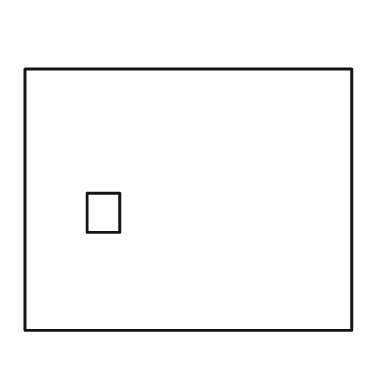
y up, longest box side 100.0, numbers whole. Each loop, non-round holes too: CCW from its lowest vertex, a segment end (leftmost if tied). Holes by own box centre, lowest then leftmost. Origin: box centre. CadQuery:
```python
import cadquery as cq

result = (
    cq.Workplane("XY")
    .moveTo(-50.0, -40.0)
    .lineTo(50.0, -40.0)
    .lineTo(50.0, 40.0)
    .lineTo(-50.0, 40.0)
    .close()
    .moveTo(-31.0, -10.0)
    .lineTo(-21.0, -10.0)
    .lineTo(-21.0, 2.0)
    .lineTo(-31.0, 2.0)
    .close()
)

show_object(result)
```